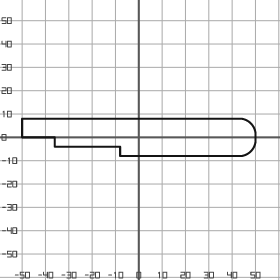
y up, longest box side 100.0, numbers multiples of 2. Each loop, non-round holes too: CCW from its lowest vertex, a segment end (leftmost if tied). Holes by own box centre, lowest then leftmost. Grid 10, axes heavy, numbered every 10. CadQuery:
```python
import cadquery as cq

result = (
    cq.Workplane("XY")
    .moveTo(-8.0, -8.0)
    .lineTo(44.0, -8.0)
    .threePointArc((48.0, -6.0), (50.0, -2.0))
    .lineTo(50.0, 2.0)
    .threePointArc((48.0, 6.0), (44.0, 8.0))
    .lineTo(-50.0, 8.0)
    .lineTo(-50.0, 0.0)
    .lineTo(-36.0, 0.0)
    .lineTo(-36.0, -4.0)
    .lineTo(-8.0, -4.0)
    .close()
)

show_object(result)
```